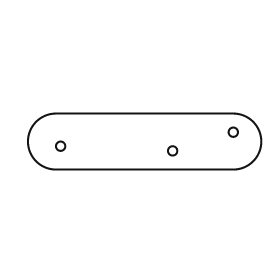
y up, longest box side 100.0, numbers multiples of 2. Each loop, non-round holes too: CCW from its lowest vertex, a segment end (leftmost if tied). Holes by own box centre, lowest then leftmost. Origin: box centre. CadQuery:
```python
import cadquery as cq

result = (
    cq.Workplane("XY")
    .moveTo(-38.0, -12.0)
    .lineTo(38.0, -12.0)
    .threePointArc((50.0, 0.0), (38.0, 12.0))
    .lineTo(-38.0, 12.0)
    .threePointArc((-50.0, 0.0), (-38.0, -12.0))
    .close()
    .moveTo(12.0, -4.0)
    .circle(2.0)
    .moveTo(-36.0, -2.0)
    .circle(2.0)
    .moveTo(38.0, 4.0)
    .circle(2.0)
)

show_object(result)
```